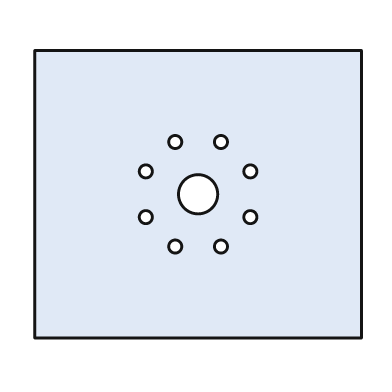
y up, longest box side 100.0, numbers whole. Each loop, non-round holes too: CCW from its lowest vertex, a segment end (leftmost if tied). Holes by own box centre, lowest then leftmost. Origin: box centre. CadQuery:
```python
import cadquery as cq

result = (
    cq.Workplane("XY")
    .moveTo(-50.0, -44.0)
    .lineTo(50.0, -44.0)
    .lineTo(50.0, 44.0)
    .lineTo(-50.0, 44.0)
    .close()
    .moveTo(-7.0, -16.0)
    .circle(2.0)
    .moveTo(7.0, -16.0)
    .circle(2.0)
    .moveTo(-16.0, -7.0)
    .circle(2.0)
    .moveTo(16.0, -7.0)
    .circle(2.0)
    .moveTo(0.0, 0.0)
    .circle(6.0)
    .moveTo(-16.0, 7.0)
    .circle(2.0)
    .moveTo(16.0, 7.0)
    .circle(2.0)
    .moveTo(-7.0, 16.0)
    .circle(2.0)
    .moveTo(7.0, 16.0)
    .circle(2.0)
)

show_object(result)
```